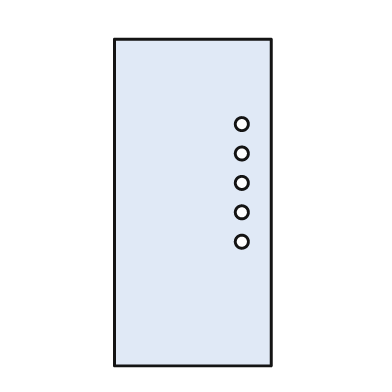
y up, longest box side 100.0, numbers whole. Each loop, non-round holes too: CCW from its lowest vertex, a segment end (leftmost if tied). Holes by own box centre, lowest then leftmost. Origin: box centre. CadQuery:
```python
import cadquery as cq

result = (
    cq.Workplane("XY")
    .moveTo(-24.0, -50.0)
    .lineTo(24.0, -50.0)
    .lineTo(24.0, 50.0)
    .lineTo(-24.0, 50.0)
    .close()
    .moveTo(15.0, -12.0)
    .circle(2.0)
    .moveTo(15.0, -3.0)
    .circle(2.0)
    .moveTo(15.0, 6.0)
    .circle(2.0)
    .moveTo(15.0, 15.0)
    .circle(2.0)
    .moveTo(15.0, 24.0)
    .circle(2.0)
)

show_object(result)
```